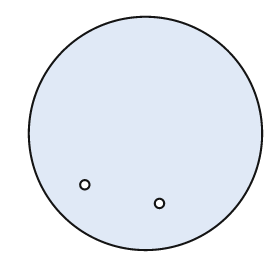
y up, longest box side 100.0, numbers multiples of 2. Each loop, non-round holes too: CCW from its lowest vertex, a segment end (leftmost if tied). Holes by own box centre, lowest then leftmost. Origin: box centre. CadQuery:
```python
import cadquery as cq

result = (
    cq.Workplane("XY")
    .moveTo(0.0, 0.0)
    .circle(50.0)
    .moveTo(6.0, -30.0)
    .circle(2.0)
    .moveTo(-26.0, -22.0)
    .circle(2.0)
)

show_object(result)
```